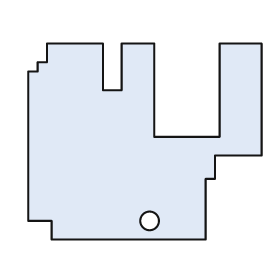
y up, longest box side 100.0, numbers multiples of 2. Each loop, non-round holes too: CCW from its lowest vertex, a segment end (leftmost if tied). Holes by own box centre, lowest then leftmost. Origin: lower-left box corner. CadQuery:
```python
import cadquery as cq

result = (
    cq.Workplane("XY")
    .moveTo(10.0, 0.0)
    .lineTo(76.0, 0.0)
    .lineTo(76.0, 26.0)
    .lineTo(80.0, 26.0)
    .lineTo(80.0, 36.0)
    .lineTo(100.0, 36.0)
    .lineTo(100.0, 84.0)
    .lineTo(82.0, 84.0)
    .lineTo(82.0, 44.0)
    .lineTo(54.0, 44.0)
    .lineTo(54.0, 84.0)
    .lineTo(40.0, 84.0)
    .lineTo(40.0, 64.0)
    .lineTo(32.0, 64.0)
    .lineTo(32.0, 84.0)
    .lineTo(8.0, 84.0)
    .lineTo(8.0, 76.0)
    .lineTo(4.0, 76.0)
    .lineTo(4.0, 72.0)
    .lineTo(0.0, 72.0)
    .lineTo(0.0, 8.0)
    .lineTo(10.0, 8.0)
    .close()
    .moveTo(52.0, 8.0)
    .circle(4.0)
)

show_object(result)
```